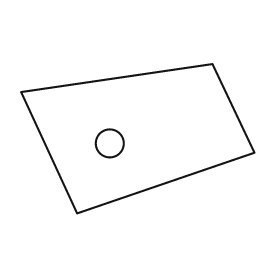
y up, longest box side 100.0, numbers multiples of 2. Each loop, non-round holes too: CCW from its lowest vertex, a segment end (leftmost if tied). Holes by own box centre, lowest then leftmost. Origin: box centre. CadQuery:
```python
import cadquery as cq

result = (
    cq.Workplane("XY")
    .moveTo(-26.0, -32.0)
    .lineTo(50.0, -6.0)
    .lineTo(32.0, 32.0)
    .lineTo(-50.0, 20.0)
    .close()
    .moveTo(-12.0, -2.0)
    .circle(6.0)
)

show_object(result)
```